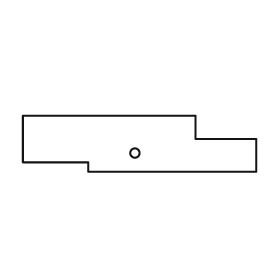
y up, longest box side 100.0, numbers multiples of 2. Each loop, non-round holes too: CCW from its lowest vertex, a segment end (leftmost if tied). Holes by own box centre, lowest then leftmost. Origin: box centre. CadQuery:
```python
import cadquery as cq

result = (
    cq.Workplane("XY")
    .moveTo(-22.0, -12.0)
    .lineTo(50.0, -12.0)
    .lineTo(50.0, 2.0)
    .lineTo(24.0, 2.0)
    .lineTo(24.0, 12.0)
    .lineTo(-50.0, 12.0)
    .lineTo(-50.0, -8.0)
    .lineTo(-22.0, -8.0)
    .close()
    .moveTo(-2.0, -4.0)
    .circle(2.0)
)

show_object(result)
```